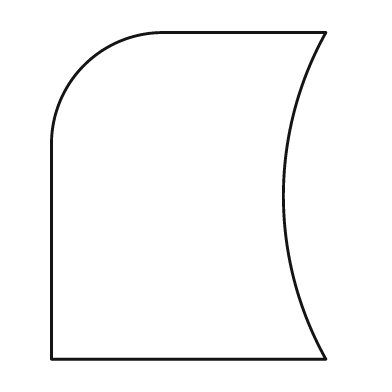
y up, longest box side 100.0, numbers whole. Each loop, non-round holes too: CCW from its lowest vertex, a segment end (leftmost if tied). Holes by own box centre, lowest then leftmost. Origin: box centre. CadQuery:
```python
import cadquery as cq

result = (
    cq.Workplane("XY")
    .moveTo(-42.0, -50.0)
    .lineTo(42.0, -50.0)
    .threePointArc((29.0, 0.0), (42.0, 50.0))
    .lineTo(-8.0, 50.0)
    .threePointArc((-32.0, 40.0), (-42.0, 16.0))
    .close()
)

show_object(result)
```